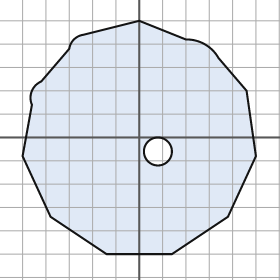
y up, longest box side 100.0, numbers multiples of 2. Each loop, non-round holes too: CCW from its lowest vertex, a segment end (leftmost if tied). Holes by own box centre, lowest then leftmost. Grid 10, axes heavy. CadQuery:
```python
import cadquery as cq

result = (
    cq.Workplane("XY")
    .moveTo(-14.0, -50.0)
    .lineTo(14.0, -50.0)
    .lineTo(38.0, -34.0)
    .lineTo(50.0, -8.0)
    .lineTo(46.0, 20.0)
    .lineTo(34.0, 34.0)
    .threePointArc((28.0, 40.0), (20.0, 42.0))
    .lineTo(0.0, 50.0)
    .lineTo(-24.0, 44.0)
    .threePointArc((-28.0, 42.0), (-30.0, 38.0))
    .lineTo(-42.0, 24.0)
    .threePointArc((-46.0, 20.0), (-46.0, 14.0))
    .lineTo(-50.0, -8.0)
    .lineTo(-38.0, -34.0)
    .close()
    .moveTo(8.0, -6.0)
    .circle(6.0)
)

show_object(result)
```